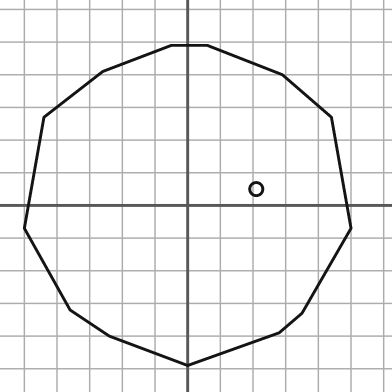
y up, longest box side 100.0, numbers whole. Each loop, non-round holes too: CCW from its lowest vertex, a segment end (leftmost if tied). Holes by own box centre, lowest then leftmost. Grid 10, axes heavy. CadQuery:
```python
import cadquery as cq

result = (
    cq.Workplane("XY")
    .moveTo(0.0, -49.0)
    .lineTo(28.0, -39.0)
    .lineTo(35.0, -33.0)
    .lineTo(50.0, -7.0)
    .lineTo(44.0, 27.0)
    .lineTo(29.0, 40.0)
    .lineTo(6.0, 49.0)
    .lineTo(-5.0, 49.0)
    .lineTo(-26.0, 41.0)
    .lineTo(-44.0, 27.0)
    .lineTo(-50.0, -7.0)
    .lineTo(-36.0, -32.0)
    .lineTo(-24.0, -40.0)
    .close()
    .moveTo(21.0, 5.0)
    .circle(2.0)
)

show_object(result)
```